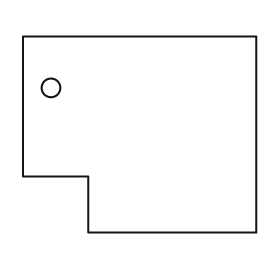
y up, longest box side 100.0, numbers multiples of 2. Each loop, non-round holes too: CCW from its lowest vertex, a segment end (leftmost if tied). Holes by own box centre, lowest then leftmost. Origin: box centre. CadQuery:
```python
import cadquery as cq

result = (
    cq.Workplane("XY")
    .moveTo(-22.0, -42.0)
    .lineTo(50.0, -42.0)
    .lineTo(50.0, 42.0)
    .lineTo(-50.0, 42.0)
    .lineTo(-50.0, -18.0)
    .lineTo(-22.0, -18.0)
    .close()
    .moveTo(-38.0, 20.0)
    .circle(4.0)
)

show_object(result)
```